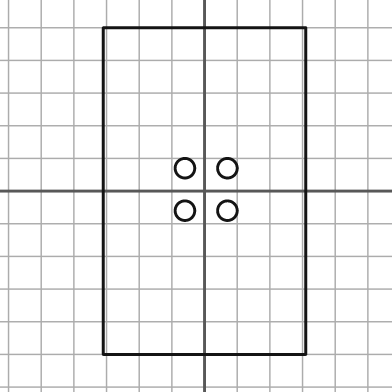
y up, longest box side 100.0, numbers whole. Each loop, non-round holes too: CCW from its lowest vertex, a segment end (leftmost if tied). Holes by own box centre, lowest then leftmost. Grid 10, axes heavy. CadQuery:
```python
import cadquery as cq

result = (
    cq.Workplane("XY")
    .moveTo(-31.0, -50.0)
    .lineTo(31.0, -50.0)
    .lineTo(31.0, 50.0)
    .lineTo(-31.0, 50.0)
    .close()
    .moveTo(-6.0, -6.0)
    .circle(3.0)
    .moveTo(7.0, -6.0)
    .circle(3.0)
    .moveTo(-6.0, 7.0)
    .circle(3.0)
    .moveTo(7.0, 7.0)
    .circle(3.0)
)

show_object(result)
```